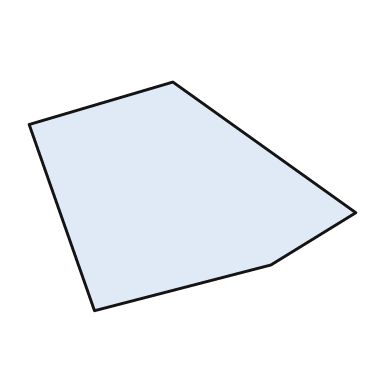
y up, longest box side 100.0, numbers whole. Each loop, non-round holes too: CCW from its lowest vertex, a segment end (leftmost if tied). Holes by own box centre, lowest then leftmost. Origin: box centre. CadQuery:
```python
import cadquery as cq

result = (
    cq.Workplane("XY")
    .moveTo(-30.0, -35.0)
    .lineTo(24.0, -21.0)
    .lineTo(50.0, -5.0)
    .lineTo(-6.0, 35.0)
    .lineTo(-50.0, 22.0)
    .close()
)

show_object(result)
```